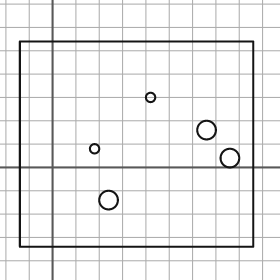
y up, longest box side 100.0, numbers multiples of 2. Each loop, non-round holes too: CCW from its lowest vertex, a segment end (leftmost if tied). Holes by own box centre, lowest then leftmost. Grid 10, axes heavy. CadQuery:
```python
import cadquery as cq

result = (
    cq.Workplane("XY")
    .moveTo(-14.0, -34.0)
    .lineTo(86.0, -34.0)
    .lineTo(86.0, 54.0)
    .lineTo(-14.0, 54.0)
    .close()
    .moveTo(24.0, -14.0)
    .circle(4.0)
    .moveTo(76.0, 4.0)
    .circle(4.0)
    .moveTo(18.0, 8.0)
    .circle(2.0)
    .moveTo(66.0, 16.0)
    .circle(4.0)
    .moveTo(42.0, 30.0)
    .circle(2.0)
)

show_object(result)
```